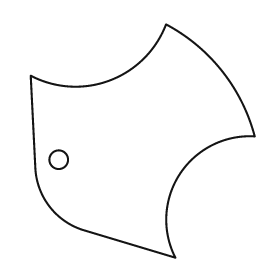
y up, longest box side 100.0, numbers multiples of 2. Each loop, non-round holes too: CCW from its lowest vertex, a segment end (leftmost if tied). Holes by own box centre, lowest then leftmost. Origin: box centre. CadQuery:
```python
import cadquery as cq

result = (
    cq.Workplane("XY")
    .moveTo(14.0, -50.0)
    .threePointArc((16.0, -14.0), (48.0, 2.0))
    .threePointArc((34.0, 30.0), (10.0, 50.0))
    .threePointArc((-14.0, 26.0), (-48.0, 28.0))
    .lineTo(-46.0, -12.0)
    .threePointArc((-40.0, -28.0), (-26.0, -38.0))
    .close()
    .moveTo(-36.0, -8.0)
    .circle(4.0)
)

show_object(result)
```